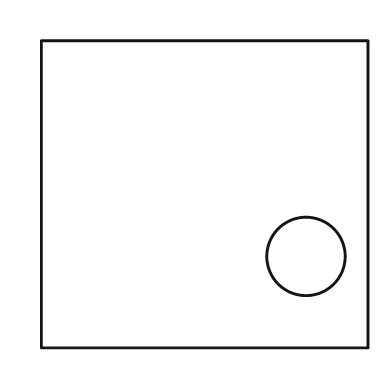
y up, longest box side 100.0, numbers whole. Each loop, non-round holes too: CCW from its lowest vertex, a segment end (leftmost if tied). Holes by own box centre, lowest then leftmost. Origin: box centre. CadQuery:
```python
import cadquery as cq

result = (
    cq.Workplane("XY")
    .moveTo(-50.0, -47.0)
    .lineTo(50.0, -47.0)
    .lineTo(50.0, 47.0)
    .lineTo(-50.0, 47.0)
    .close()
    .moveTo(31.0, -19.0)
    .circle(12.0)
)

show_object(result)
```